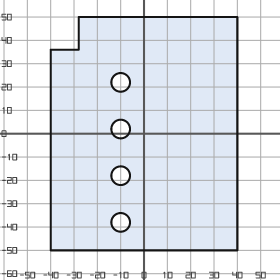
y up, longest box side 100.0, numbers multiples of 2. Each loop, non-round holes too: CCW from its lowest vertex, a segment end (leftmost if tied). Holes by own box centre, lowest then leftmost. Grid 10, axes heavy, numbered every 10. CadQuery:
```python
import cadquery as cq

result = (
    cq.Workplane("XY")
    .moveTo(-40.0, -50.0)
    .lineTo(40.0, -50.0)
    .lineTo(40.0, 50.0)
    .lineTo(-28.0, 50.0)
    .lineTo(-28.0, 36.0)
    .lineTo(-40.0, 36.0)
    .close()
    .moveTo(-10.0, -38.0)
    .circle(4.0)
    .moveTo(-10.0, -18.0)
    .circle(4.0)
    .moveTo(-10.0, 2.0)
    .circle(4.0)
    .moveTo(-10.0, 22.0)
    .circle(4.0)
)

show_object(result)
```